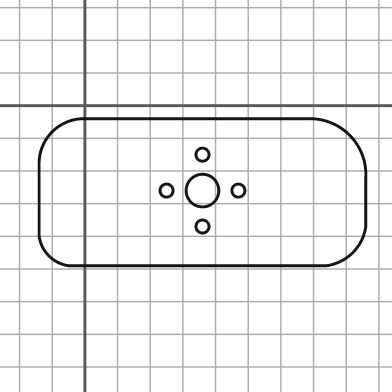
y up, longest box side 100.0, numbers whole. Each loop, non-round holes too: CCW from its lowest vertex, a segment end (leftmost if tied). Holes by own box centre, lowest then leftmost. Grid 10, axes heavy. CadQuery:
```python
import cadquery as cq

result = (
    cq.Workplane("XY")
    .moveTo(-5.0, -49.0)
    .lineTo(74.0, -49.0)
    .threePointArc((82.0, -45.0), (86.0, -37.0))
    .lineTo(86.0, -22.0)
    .threePointArc((81.0, -9.0), (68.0, -4.0))
    .lineTo(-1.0, -4.0)
    .threePointArc((-10.0, -8.0), (-14.0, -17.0))
    .lineTo(-14.0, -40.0)
    .threePointArc((-11.0, -46.0), (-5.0, -49.0))
    .close()
    .moveTo(36.0, -37.0)
    .circle(2.0)
    .moveTo(25.0, -26.0)
    .circle(2.0)
    .moveTo(36.0, -26.0)
    .circle(5.0)
    .moveTo(47.0, -26.0)
    .circle(2.0)
    .moveTo(36.0, -15.0)
    .circle(2.0)
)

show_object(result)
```